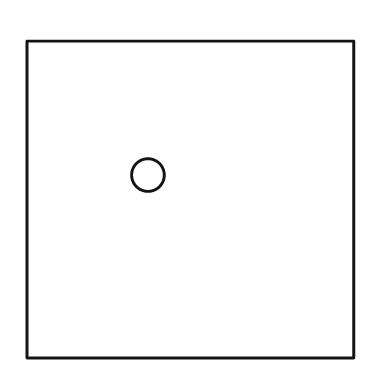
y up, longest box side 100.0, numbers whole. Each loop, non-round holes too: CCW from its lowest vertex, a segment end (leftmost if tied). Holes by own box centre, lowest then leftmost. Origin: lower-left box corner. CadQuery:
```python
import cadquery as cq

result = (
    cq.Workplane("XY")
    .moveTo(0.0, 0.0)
    .lineTo(100.0, 0.0)
    .lineTo(100.0, 97.0)
    .lineTo(0.0, 97.0)
    .close()
    .moveTo(37.0, 56.0)
    .circle(5.0)
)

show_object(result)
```